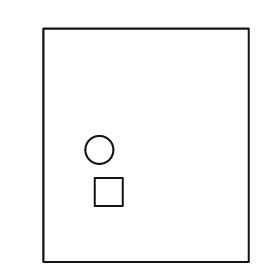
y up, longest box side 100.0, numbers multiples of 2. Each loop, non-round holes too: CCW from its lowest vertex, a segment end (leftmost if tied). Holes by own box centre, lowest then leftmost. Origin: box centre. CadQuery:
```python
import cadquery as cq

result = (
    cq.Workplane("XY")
    .moveTo(-44.0, -50.0)
    .lineTo(44.0, -50.0)
    .lineTo(44.0, 50.0)
    .lineTo(-44.0, 50.0)
    .close()
    .moveTo(-22.0, -26.0)
    .lineTo(-10.0, -26.0)
    .lineTo(-10.0, -14.0)
    .lineTo(-22.0, -14.0)
    .close()
    .moveTo(-20.0, -2.0)
    .circle(6.0)
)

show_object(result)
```